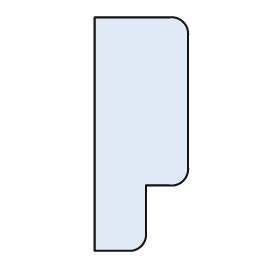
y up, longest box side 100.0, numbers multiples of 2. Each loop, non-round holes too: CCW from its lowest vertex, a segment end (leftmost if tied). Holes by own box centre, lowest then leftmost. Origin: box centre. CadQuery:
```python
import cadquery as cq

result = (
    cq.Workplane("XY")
    .moveTo(-20.0, -50.0)
    .lineTo(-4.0, -50.0)
    .threePointArc((0.0, -48.0), (2.0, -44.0))
    .lineTo(2.0, -22.0)
    .lineTo(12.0, -22.0)
    .threePointArc((18.0, -20.0), (20.0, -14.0))
    .lineTo(20.0, 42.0)
    .threePointArc((18.0, 48.0), (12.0, 50.0))
    .lineTo(-20.0, 50.0)
    .close()
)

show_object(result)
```